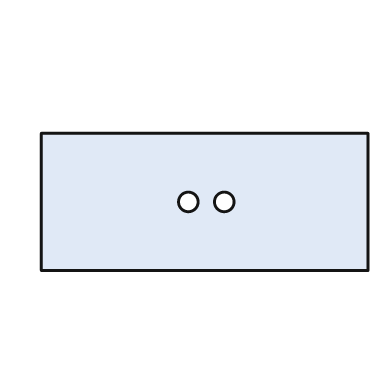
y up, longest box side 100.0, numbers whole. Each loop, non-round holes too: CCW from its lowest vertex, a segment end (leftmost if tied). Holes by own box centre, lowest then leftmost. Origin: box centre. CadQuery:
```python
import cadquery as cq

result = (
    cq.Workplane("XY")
    .moveTo(-50.0, -21.0)
    .lineTo(50.0, -21.0)
    .lineTo(50.0, 21.0)
    .lineTo(-50.0, 21.0)
    .close()
    .moveTo(-5.0, 0.0)
    .circle(3.0)
    .moveTo(6.0, 0.0)
    .circle(3.0)
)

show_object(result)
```